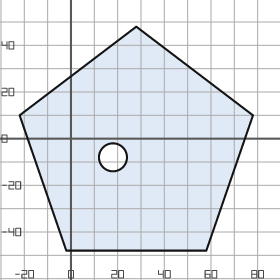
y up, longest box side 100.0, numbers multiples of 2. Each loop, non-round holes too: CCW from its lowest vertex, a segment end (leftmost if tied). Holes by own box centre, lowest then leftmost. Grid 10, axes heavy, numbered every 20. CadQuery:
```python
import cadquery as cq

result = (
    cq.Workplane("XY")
    .moveTo(-2.0, -48.0)
    .lineTo(58.0, -48.0)
    .lineTo(78.0, 10.0)
    .lineTo(28.0, 48.0)
    .lineTo(-22.0, 10.0)
    .close()
    .moveTo(18.0, -8.0)
    .circle(6.0)
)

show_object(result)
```